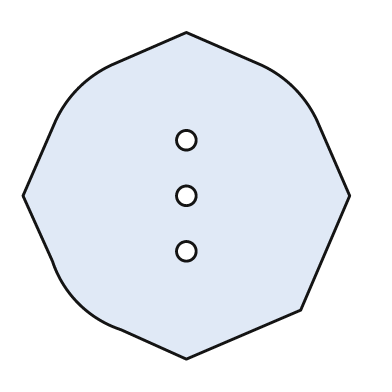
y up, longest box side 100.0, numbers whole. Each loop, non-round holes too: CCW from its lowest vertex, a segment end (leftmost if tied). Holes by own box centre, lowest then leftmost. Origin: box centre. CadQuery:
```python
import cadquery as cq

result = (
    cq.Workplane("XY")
    .moveTo(0.0, -50.0)
    .lineTo(35.0, -35.0)
    .lineTo(50.0, 0.0)
    .lineTo(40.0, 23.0)
    .threePointArc((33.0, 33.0), (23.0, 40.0))
    .lineTo(0.0, 50.0)
    .lineTo(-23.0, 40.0)
    .threePointArc((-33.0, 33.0), (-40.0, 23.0))
    .lineTo(-50.0, 0.0)
    .lineTo(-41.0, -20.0)
    .threePointArc((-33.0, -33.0), (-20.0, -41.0))
    .close()
    .moveTo(0.0, -17.0)
    .circle(3.0)
    .moveTo(0.0, 0.0)
    .circle(3.0)
    .moveTo(0.0, 17.0)
    .circle(3.0)
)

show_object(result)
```